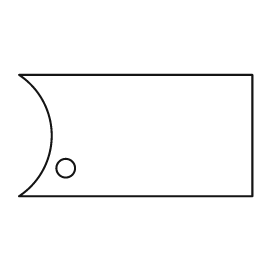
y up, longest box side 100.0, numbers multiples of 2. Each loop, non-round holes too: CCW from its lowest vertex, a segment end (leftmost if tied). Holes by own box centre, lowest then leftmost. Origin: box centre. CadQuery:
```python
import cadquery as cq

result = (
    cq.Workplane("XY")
    .moveTo(-50.0, -26.0)
    .lineTo(50.0, -26.0)
    .lineTo(50.0, 26.0)
    .lineTo(-50.0, 26.0)
    .threePointArc((-36.0, 0.0), (-50.0, -26.0))
    .close()
    .moveTo(-30.0, -14.0)
    .circle(4.0)
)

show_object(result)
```